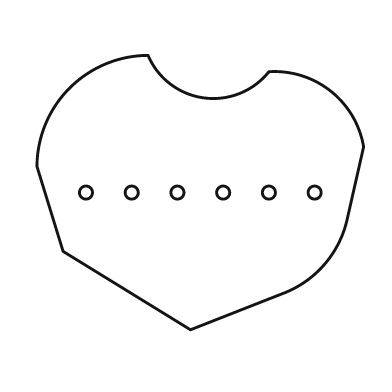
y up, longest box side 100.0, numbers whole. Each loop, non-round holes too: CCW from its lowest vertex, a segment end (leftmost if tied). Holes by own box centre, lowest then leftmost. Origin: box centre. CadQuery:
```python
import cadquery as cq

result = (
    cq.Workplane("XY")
    .moveTo(-3.0, -42.0)
    .lineTo(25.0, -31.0)
    .threePointArc((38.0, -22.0), (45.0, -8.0))
    .lineTo(50.0, 14.0)
    .threePointArc((40.0, 31.0), (21.0, 37.0))
    .threePointArc((1.0, 29.0), (-16.0, 42.0))
    .threePointArc((-40.0, 32.0), (-50.0, 8.0))
    .lineTo(-42.0, -18.0)
    .close()
    .moveTo(-35.0, 0.0)
    .circle(2.0)
    .moveTo(-21.0, 0.0)
    .circle(2.0)
    .moveTo(-7.0, 0.0)
    .circle(2.0)
    .moveTo(7.0, 0.0)
    .circle(2.0)
    .moveTo(21.0, 0.0)
    .circle(2.0)
    .moveTo(35.0, 0.0)
    .circle(2.0)
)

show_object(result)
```